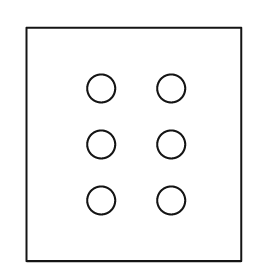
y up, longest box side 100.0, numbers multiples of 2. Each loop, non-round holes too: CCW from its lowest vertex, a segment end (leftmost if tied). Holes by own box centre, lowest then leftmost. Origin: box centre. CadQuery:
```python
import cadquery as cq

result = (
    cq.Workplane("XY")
    .moveTo(-46.0, -50.0)
    .lineTo(46.0, -50.0)
    .lineTo(46.0, 50.0)
    .lineTo(-46.0, 50.0)
    .close()
    .moveTo(-14.0, -24.0)
    .circle(6.0)
    .moveTo(16.0, -24.0)
    .circle(6.0)
    .moveTo(-14.0, 0.0)
    .circle(6.0)
    .moveTo(16.0, 0.0)
    .circle(6.0)
    .moveTo(-14.0, 24.0)
    .circle(6.0)
    .moveTo(16.0, 24.0)
    .circle(6.0)
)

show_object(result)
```